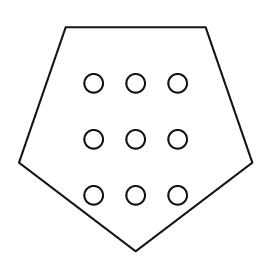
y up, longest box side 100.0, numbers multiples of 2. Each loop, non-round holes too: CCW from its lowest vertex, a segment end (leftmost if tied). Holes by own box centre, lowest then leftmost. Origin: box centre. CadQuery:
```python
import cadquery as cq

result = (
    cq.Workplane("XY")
    .moveTo(0.0, -48.0)
    .lineTo(50.0, -10.0)
    .lineTo(30.0, 48.0)
    .lineTo(-30.0, 48.0)
    .lineTo(-50.0, -10.0)
    .close()
    .moveTo(-18.0, -24.0)
    .circle(4.0)
    .moveTo(0.0, -24.0)
    .circle(4.0)
    .moveTo(18.0, -24.0)
    .circle(4.0)
    .moveTo(-18.0, 0.0)
    .circle(4.0)
    .moveTo(0.0, 0.0)
    .circle(4.0)
    .moveTo(18.0, 0.0)
    .circle(4.0)
    .moveTo(-18.0, 24.0)
    .circle(4.0)
    .moveTo(0.0, 24.0)
    .circle(4.0)
    .moveTo(18.0, 24.0)
    .circle(4.0)
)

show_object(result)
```